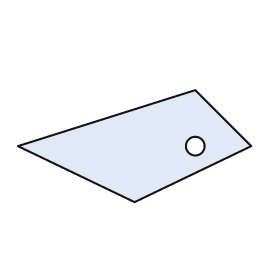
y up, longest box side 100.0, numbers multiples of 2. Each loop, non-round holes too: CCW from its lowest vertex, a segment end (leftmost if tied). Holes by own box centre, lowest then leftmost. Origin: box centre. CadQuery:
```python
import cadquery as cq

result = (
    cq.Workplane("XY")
    .moveTo(0.0, -24.0)
    .lineTo(50.0, 0.0)
    .lineTo(26.0, 24.0)
    .lineTo(-50.0, 0.0)
    .close()
    .moveTo(26.0, 0.0)
    .circle(4.0)
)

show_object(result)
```